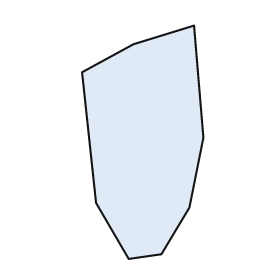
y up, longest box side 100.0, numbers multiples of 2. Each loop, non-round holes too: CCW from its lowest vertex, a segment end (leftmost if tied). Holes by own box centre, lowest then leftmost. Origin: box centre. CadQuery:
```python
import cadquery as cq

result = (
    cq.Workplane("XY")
    .moveTo(-6.0, -50.0)
    .lineTo(8.0, -48.0)
    .lineTo(20.0, -28.0)
    .lineTo(26.0, 2.0)
    .lineTo(22.0, 50.0)
    .lineTo(-4.0, 42.0)
    .lineTo(-26.0, 30.0)
    .lineTo(-20.0, -26.0)
    .close()
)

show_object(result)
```